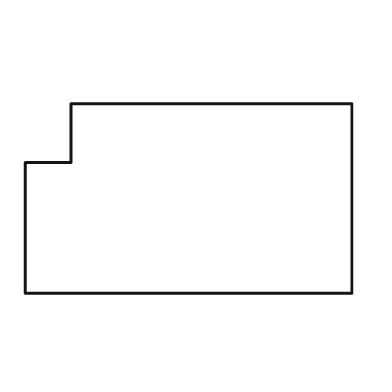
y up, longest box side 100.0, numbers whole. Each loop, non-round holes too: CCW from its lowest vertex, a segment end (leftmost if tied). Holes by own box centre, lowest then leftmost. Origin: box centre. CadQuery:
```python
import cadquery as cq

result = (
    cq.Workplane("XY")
    .moveTo(-50.0, -29.0)
    .lineTo(50.0, -29.0)
    .lineTo(50.0, 29.0)
    .lineTo(-36.0, 29.0)
    .lineTo(-36.0, 11.0)
    .lineTo(-50.0, 11.0)
    .close()
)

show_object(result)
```